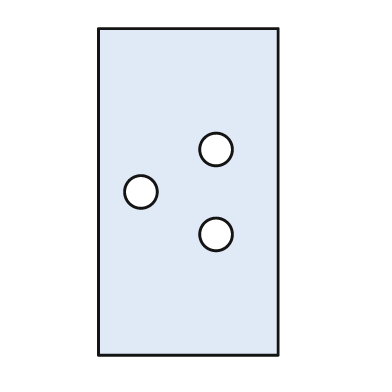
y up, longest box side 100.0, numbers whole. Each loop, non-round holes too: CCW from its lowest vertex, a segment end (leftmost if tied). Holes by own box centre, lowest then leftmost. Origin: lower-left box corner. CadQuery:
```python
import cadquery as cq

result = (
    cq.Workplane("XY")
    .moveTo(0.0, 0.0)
    .lineTo(55.0, 0.0)
    .lineTo(55.0, 100.0)
    .lineTo(0.0, 100.0)
    .close()
    .moveTo(36.0, 37.0)
    .circle(5.0)
    .moveTo(13.0, 50.0)
    .circle(5.0)
    .moveTo(36.0, 63.0)
    .circle(5.0)
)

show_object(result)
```